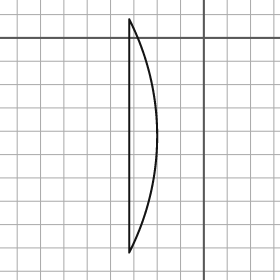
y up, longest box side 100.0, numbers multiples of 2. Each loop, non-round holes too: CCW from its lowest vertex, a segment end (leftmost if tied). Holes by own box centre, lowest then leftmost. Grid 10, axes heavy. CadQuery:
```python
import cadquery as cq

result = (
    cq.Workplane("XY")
    .moveTo(-32.0, -92.0)
    .threePointArc((-20.0, -42.0), (-32.0, 8.0))
    .close()
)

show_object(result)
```